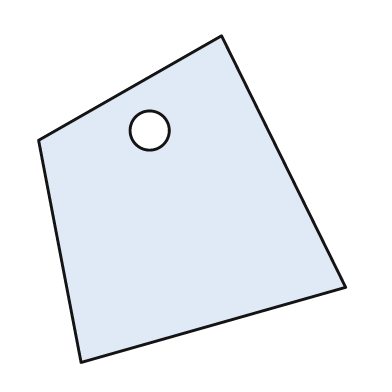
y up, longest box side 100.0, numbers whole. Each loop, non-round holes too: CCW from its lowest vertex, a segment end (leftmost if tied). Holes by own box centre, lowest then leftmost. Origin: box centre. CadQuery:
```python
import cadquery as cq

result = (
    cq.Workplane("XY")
    .moveTo(-34.0, -50.0)
    .lineTo(47.0, -27.0)
    .lineTo(9.0, 50.0)
    .lineTo(-47.0, 18.0)
    .close()
    .moveTo(-13.0, 21.0)
    .circle(6.0)
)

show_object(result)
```